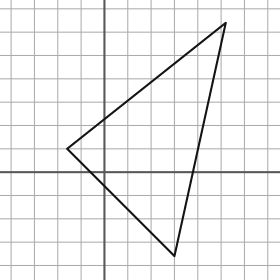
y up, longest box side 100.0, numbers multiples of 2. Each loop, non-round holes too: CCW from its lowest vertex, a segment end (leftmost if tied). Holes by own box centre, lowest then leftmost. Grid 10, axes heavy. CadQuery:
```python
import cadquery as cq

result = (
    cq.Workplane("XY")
    .moveTo(30.0, -36.0)
    .lineTo(52.0, 64.0)
    .lineTo(-16.0, 10.0)
    .close()
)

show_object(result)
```